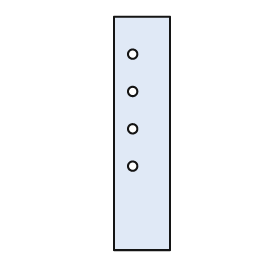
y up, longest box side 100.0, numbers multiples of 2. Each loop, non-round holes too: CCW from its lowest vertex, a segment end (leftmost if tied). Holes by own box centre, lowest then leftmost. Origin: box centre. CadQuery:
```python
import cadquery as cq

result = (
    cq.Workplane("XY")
    .moveTo(-12.0, -50.0)
    .lineTo(12.0, -50.0)
    .lineTo(12.0, 50.0)
    .lineTo(-12.0, 50.0)
    .close()
    .moveTo(-4.0, -14.0)
    .circle(2.0)
    .moveTo(-4.0, 2.0)
    .circle(2.0)
    .moveTo(-4.0, 18.0)
    .circle(2.0)
    .moveTo(-4.0, 34.0)
    .circle(2.0)
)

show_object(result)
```